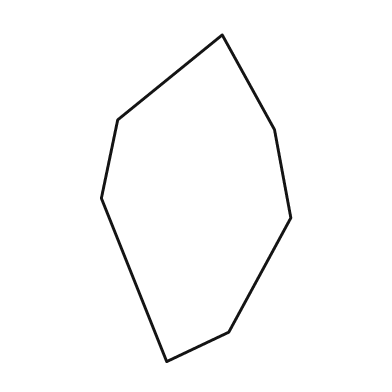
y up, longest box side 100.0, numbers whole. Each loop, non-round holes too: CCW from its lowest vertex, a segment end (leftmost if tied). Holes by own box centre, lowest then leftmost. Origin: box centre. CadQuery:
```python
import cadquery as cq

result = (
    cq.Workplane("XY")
    .moveTo(-9.0, -50.0)
    .lineTo(10.0, -41.0)
    .lineTo(29.0, -6.0)
    .lineTo(24.0, 21.0)
    .lineTo(8.0, 50.0)
    .lineTo(-24.0, 24.0)
    .lineTo(-29.0, 0.0)
    .close()
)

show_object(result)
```